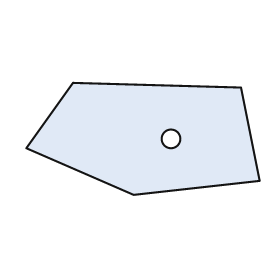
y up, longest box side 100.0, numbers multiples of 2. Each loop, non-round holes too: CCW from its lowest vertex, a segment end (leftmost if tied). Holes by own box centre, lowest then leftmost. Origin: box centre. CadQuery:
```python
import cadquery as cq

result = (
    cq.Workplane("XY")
    .moveTo(-4.0, -24.0)
    .lineTo(50.0, -18.0)
    .lineTo(42.0, 22.0)
    .lineTo(-30.0, 24.0)
    .lineTo(-50.0, -4.0)
    .close()
    .moveTo(12.0, 0.0)
    .circle(4.0)
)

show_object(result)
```